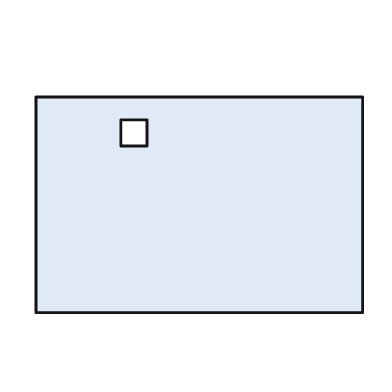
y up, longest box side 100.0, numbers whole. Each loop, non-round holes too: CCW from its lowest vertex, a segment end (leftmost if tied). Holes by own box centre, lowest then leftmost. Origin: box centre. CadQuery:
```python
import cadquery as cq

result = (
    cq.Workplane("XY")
    .moveTo(-50.0, -33.0)
    .lineTo(50.0, -33.0)
    .lineTo(50.0, 33.0)
    .lineTo(-50.0, 33.0)
    .close()
    .moveTo(-24.0, 18.0)
    .lineTo(-16.0, 18.0)
    .lineTo(-16.0, 26.0)
    .lineTo(-24.0, 26.0)
    .close()
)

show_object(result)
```